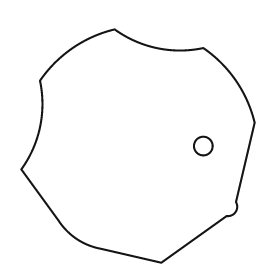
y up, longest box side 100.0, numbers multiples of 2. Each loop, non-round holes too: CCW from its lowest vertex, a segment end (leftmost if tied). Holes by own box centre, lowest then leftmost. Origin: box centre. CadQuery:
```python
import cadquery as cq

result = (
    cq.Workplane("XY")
    .moveTo(10.0, -50.0)
    .lineTo(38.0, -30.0)
    .threePointArc((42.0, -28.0), (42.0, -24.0))
    .lineTo(50.0, 10.0)
    .threePointArc((42.0, 28.0), (28.0, 42.0))
    .threePointArc((8.0, 42.0), (-10.0, 50.0))
    .threePointArc((-28.0, 42.0), (-42.0, 28.0))
    .threePointArc((-42.0, 8.0), (-50.0, -10.0))
    .lineTo(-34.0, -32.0)
    .threePointArc((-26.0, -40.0), (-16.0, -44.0))
    .close()
    .moveTo(28.0, 0.0)
    .circle(4.0)
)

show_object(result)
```